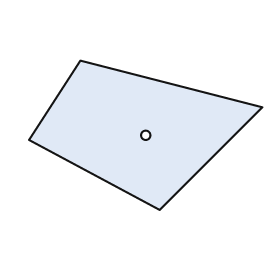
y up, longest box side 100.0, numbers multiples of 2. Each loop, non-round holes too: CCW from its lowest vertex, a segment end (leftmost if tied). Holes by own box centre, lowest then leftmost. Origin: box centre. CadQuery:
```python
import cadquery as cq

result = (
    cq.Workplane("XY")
    .moveTo(6.0, -32.0)
    .lineTo(50.0, 12.0)
    .lineTo(-28.0, 32.0)
    .lineTo(-50.0, -2.0)
    .close()
    .moveTo(0.0, 0.0)
    .circle(2.0)
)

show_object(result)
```